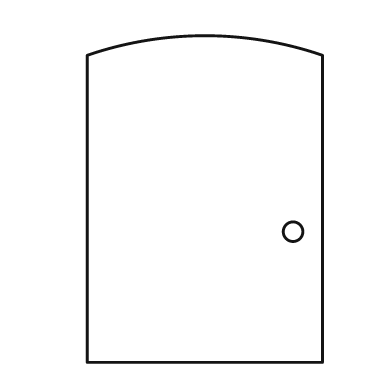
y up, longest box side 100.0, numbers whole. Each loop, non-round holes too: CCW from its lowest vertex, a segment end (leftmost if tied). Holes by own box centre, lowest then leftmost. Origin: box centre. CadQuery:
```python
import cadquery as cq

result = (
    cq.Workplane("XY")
    .moveTo(-36.0, -50.0)
    .lineTo(36.0, -50.0)
    .lineTo(36.0, 44.0)
    .threePointArc((0.0, 50.0), (-36.0, 44.0))
    .close()
    .moveTo(27.0, -10.0)
    .circle(3.0)
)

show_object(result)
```